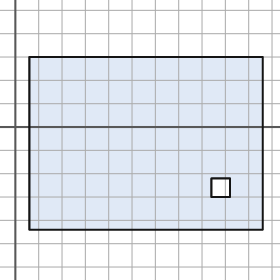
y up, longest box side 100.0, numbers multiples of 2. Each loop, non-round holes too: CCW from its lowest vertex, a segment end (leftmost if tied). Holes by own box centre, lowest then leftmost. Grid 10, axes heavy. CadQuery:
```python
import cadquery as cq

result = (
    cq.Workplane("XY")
    .moveTo(6.0, -44.0)
    .lineTo(106.0, -44.0)
    .lineTo(106.0, 30.0)
    .lineTo(6.0, 30.0)
    .close()
    .moveTo(84.0, -30.0)
    .lineTo(92.0, -30.0)
    .lineTo(92.0, -22.0)
    .lineTo(84.0, -22.0)
    .close()
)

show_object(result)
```